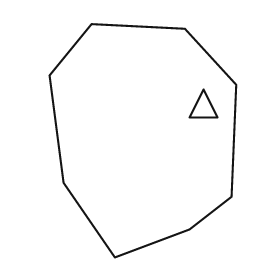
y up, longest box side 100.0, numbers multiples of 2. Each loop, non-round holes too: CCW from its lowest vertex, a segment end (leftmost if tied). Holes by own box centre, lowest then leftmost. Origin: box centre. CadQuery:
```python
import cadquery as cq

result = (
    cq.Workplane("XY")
    .moveTo(-12.0, -50.0)
    .lineTo(20.0, -38.0)
    .lineTo(38.0, -24.0)
    .lineTo(40.0, 24.0)
    .lineTo(18.0, 48.0)
    .lineTo(-22.0, 50.0)
    .lineTo(-40.0, 28.0)
    .lineTo(-34.0, -18.0)
    .close()
    .moveTo(20.0, 10.0)
    .lineTo(32.0, 10.0)
    .lineTo(26.0, 22.0)
    .close()
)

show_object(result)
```